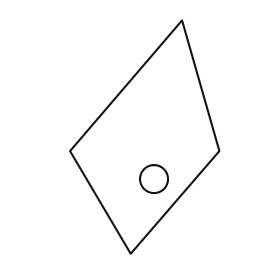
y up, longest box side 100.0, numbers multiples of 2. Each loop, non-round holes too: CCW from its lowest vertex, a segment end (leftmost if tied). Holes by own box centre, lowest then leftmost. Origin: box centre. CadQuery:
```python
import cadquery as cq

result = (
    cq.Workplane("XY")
    .moveTo(-6.0, -50.0)
    .lineTo(32.0, -6.0)
    .lineTo(16.0, 50.0)
    .lineTo(-32.0, -6.0)
    .close()
    .moveTo(4.0, -18.0)
    .circle(6.0)
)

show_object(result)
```